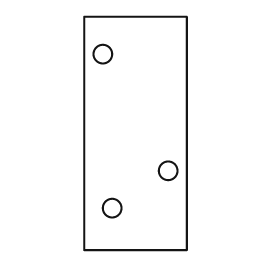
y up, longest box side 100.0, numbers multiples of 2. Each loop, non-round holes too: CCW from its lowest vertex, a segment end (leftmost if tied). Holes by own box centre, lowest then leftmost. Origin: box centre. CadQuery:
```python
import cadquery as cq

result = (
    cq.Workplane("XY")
    .moveTo(-22.0, -50.0)
    .lineTo(22.0, -50.0)
    .lineTo(22.0, 50.0)
    .lineTo(-22.0, 50.0)
    .close()
    .moveTo(-10.0, -32.0)
    .circle(4.0)
    .moveTo(14.0, -16.0)
    .circle(4.0)
    .moveTo(-14.0, 34.0)
    .circle(4.0)
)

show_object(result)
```